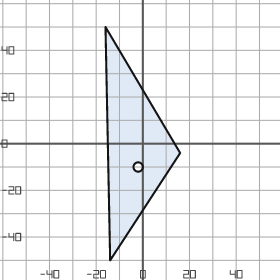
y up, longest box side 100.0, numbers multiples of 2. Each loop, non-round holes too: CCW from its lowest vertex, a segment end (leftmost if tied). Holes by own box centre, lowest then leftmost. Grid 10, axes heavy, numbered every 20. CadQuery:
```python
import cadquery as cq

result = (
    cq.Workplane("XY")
    .moveTo(-14.0, -50.0)
    .lineTo(16.0, -4.0)
    .lineTo(-16.0, 50.0)
    .close()
    .moveTo(-2.0, -10.0)
    .circle(2.0)
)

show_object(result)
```